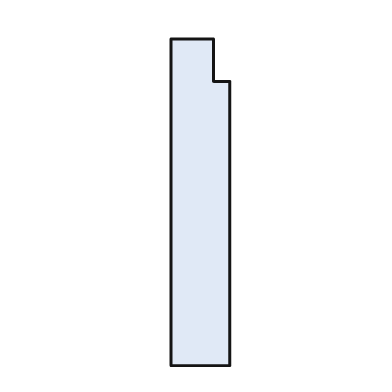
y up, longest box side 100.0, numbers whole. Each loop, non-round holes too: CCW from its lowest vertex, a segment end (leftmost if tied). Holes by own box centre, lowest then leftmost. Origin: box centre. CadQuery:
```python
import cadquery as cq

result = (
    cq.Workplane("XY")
    .moveTo(-9.0, -50.0)
    .lineTo(9.0, -50.0)
    .lineTo(9.0, 37.0)
    .lineTo(4.0, 37.0)
    .lineTo(4.0, 50.0)
    .lineTo(-9.0, 50.0)
    .close()
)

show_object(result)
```